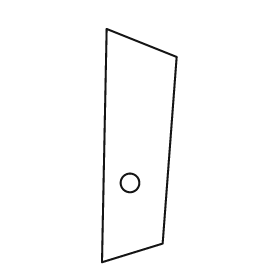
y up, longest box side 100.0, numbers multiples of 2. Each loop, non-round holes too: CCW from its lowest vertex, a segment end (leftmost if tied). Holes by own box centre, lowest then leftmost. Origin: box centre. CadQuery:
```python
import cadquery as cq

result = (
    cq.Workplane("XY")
    .moveTo(-16.0, -50.0)
    .lineTo(10.0, -42.0)
    .lineTo(16.0, 38.0)
    .lineTo(-14.0, 50.0)
    .close()
    .moveTo(-4.0, -16.0)
    .circle(4.0)
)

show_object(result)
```